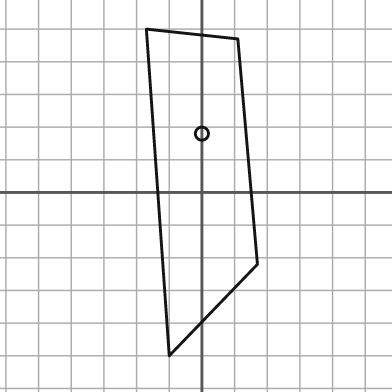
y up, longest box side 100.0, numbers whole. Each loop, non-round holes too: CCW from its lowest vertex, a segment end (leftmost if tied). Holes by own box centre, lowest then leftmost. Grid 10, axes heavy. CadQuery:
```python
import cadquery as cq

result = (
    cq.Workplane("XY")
    .moveTo(-10.0, -50.0)
    .lineTo(17.0, -22.0)
    .lineTo(11.0, 47.0)
    .lineTo(-17.0, 50.0)
    .close()
    .moveTo(0.0, 18.0)
    .circle(2.0)
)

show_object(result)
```